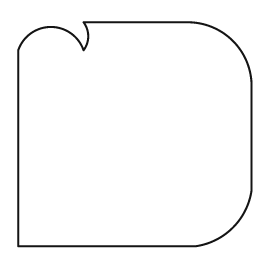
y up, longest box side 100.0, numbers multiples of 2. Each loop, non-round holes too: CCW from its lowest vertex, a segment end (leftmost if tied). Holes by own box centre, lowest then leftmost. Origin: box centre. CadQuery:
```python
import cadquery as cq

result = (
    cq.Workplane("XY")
    .moveTo(-50.0, -48.0)
    .lineTo(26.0, -48.0)
    .threePointArc((42.0, -40.0), (50.0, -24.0))
    .lineTo(50.0, 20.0)
    .threePointArc((42.0, 40.0), (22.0, 48.0))
    .lineTo(-22.0, 48.0)
    .threePointArc((-20.0, 42.0), (-22.0, 36.0))
    .threePointArc((-36.0, 46.0), (-50.0, 36.0))
    .close()
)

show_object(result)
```